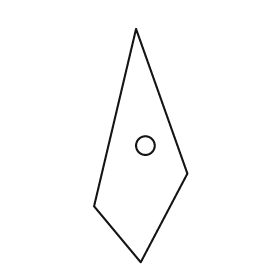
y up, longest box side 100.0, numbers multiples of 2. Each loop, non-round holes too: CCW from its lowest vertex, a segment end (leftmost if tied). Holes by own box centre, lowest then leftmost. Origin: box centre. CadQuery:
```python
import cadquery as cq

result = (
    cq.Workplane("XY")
    .moveTo(0.0, -50.0)
    .lineTo(20.0, -12.0)
    .lineTo(-2.0, 50.0)
    .lineTo(-20.0, -26.0)
    .close()
    .moveTo(2.0, 0.0)
    .circle(4.0)
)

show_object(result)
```